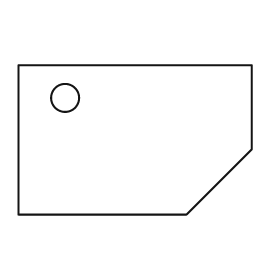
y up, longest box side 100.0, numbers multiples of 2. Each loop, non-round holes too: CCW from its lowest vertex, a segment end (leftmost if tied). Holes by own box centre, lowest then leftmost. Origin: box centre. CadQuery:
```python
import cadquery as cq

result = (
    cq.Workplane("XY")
    .moveTo(-50.0, -32.0)
    .lineTo(22.0, -32.0)
    .lineTo(50.0, -4.0)
    .lineTo(50.0, 32.0)
    .lineTo(-50.0, 32.0)
    .close()
    .moveTo(-30.0, 18.0)
    .circle(6.0)
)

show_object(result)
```